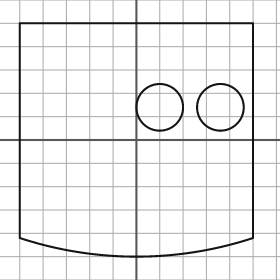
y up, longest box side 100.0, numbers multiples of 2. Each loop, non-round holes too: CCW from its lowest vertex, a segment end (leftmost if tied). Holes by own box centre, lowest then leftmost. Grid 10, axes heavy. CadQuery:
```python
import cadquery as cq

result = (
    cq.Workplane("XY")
    .moveTo(-50.0, -42.0)
    .threePointArc((0.0, -50.0), (50.0, -42.0))
    .lineTo(50.0, 50.0)
    .lineTo(-50.0, 50.0)
    .close()
    .moveTo(10.0, 14.0)
    .circle(10.0)
    .moveTo(36.0, 14.0)
    .circle(10.0)
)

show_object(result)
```